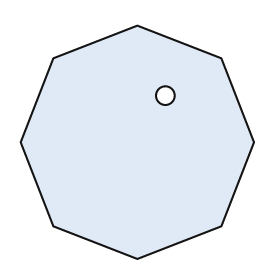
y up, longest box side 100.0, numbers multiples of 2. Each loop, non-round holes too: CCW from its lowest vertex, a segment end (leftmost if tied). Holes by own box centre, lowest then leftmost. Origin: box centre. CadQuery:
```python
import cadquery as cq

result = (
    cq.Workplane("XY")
    .moveTo(0.0, -50.0)
    .lineTo(36.0, -36.0)
    .lineTo(50.0, 0.0)
    .lineTo(36.0, 36.0)
    .lineTo(0.0, 50.0)
    .lineTo(-36.0, 36.0)
    .lineTo(-50.0, 0.0)
    .lineTo(-36.0, -36.0)
    .close()
    .moveTo(12.0, 20.0)
    .circle(4.0)
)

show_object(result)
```